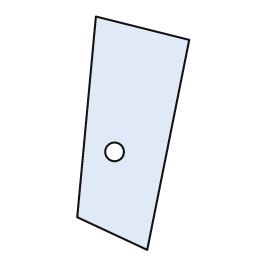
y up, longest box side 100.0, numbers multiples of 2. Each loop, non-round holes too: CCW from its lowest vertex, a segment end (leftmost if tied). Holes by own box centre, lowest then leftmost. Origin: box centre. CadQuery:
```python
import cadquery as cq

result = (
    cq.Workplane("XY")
    .moveTo(6.0, -50.0)
    .lineTo(24.0, 40.0)
    .lineTo(-16.0, 50.0)
    .lineTo(-24.0, -36.0)
    .close()
    .moveTo(-8.0, -8.0)
    .circle(4.0)
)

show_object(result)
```